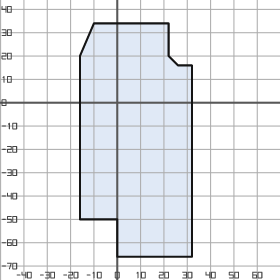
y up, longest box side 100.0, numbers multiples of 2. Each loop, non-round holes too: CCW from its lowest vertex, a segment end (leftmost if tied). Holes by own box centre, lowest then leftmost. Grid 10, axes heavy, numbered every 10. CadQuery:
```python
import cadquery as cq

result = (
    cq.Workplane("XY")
    .moveTo(0.0, -66.0)
    .lineTo(32.0, -66.0)
    .lineTo(32.0, 16.0)
    .lineTo(26.0, 16.0)
    .lineTo(22.0, 20.0)
    .lineTo(22.0, 34.0)
    .lineTo(-10.0, 34.0)
    .lineTo(-16.0, 20.0)
    .lineTo(-16.0, -50.0)
    .lineTo(0.0, -50.0)
    .close()
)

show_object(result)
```